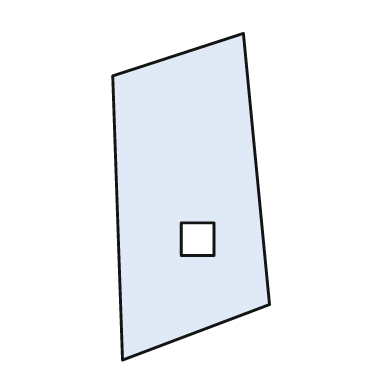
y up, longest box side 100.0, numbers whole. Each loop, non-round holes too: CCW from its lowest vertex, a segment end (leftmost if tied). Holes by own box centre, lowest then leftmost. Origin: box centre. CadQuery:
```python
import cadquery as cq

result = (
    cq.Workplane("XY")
    .moveTo(-21.0, -50.0)
    .lineTo(24.0, -33.0)
    .lineTo(16.0, 50.0)
    .lineTo(-24.0, 37.0)
    .close()
    .moveTo(-3.0, -18.0)
    .lineTo(7.0, -18.0)
    .lineTo(7.0, -8.0)
    .lineTo(-3.0, -8.0)
    .close()
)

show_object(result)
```